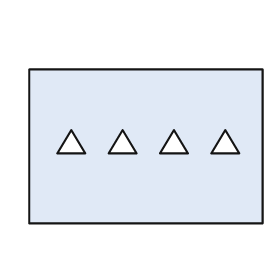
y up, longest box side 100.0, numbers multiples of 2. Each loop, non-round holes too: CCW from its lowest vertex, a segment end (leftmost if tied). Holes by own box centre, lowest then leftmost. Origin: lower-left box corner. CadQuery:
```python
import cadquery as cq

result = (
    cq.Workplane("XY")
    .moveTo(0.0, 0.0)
    .lineTo(100.0, 0.0)
    .lineTo(100.0, 66.0)
    .lineTo(0.0, 66.0)
    .close()
    .moveTo(12.0, 30.0)
    .lineTo(24.0, 30.0)
    .lineTo(18.0, 40.0)
    .close()
    .moveTo(34.0, 30.0)
    .lineTo(46.0, 30.0)
    .lineTo(40.0, 40.0)
    .close()
    .moveTo(56.0, 30.0)
    .lineTo(68.0, 30.0)
    .lineTo(62.0, 40.0)
    .close()
    .moveTo(78.0, 30.0)
    .lineTo(90.0, 30.0)
    .lineTo(84.0, 40.0)
    .close()
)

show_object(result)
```